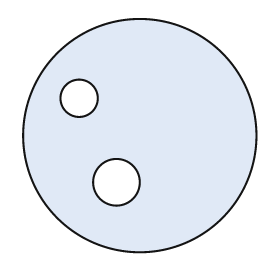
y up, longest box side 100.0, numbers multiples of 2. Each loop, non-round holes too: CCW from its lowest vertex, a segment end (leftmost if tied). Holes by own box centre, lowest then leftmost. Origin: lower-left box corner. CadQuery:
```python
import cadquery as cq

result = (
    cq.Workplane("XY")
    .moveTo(50.0, 50.0)
    .circle(50.0)
    .moveTo(40.0, 30.0)
    .circle(10.0)
    .moveTo(24.0, 66.0)
    .circle(8.0)
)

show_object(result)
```